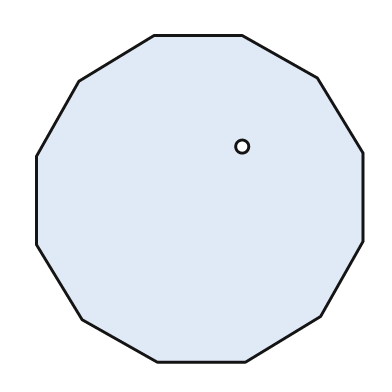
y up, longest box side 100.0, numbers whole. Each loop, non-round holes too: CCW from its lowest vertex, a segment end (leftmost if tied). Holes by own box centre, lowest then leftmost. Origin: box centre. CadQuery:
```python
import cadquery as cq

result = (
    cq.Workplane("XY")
    .moveTo(-13.0, -50.0)
    .lineTo(14.0, -50.0)
    .lineTo(37.0, -36.0)
    .lineTo(50.0, -13.0)
    .lineTo(50.0, 14.0)
    .lineTo(36.0, 37.0)
    .lineTo(13.0, 50.0)
    .lineTo(-14.0, 50.0)
    .lineTo(-37.0, 36.0)
    .lineTo(-50.0, 13.0)
    .lineTo(-50.0, -14.0)
    .lineTo(-36.0, -37.0)
    .close()
    .moveTo(13.0, 16.0)
    .circle(2.0)
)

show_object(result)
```